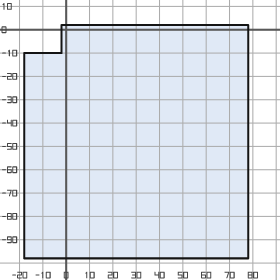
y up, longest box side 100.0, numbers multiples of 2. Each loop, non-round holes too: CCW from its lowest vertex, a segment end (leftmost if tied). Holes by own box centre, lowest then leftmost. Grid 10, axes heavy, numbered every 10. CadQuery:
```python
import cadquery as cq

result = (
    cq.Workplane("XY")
    .moveTo(-18.0, -98.0)
    .lineTo(78.0, -98.0)
    .lineTo(78.0, 2.0)
    .lineTo(-2.0, 2.0)
    .lineTo(-2.0, -10.0)
    .lineTo(-18.0, -10.0)
    .close()
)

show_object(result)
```